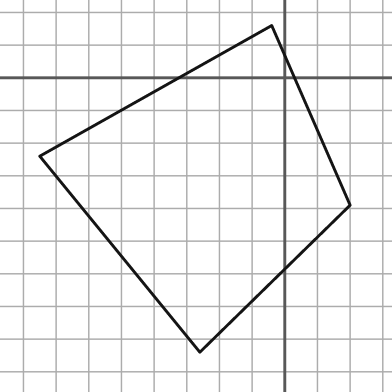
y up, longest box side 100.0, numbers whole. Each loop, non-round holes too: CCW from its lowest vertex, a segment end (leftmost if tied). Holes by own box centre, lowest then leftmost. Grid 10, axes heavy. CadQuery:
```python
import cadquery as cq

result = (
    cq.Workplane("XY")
    .moveTo(-26.0, -84.0)
    .lineTo(20.0, -39.0)
    .lineTo(-4.0, 16.0)
    .lineTo(-75.0, -24.0)
    .close()
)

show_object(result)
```